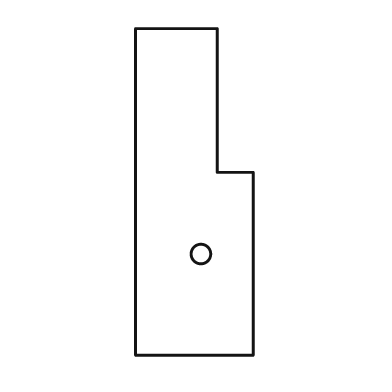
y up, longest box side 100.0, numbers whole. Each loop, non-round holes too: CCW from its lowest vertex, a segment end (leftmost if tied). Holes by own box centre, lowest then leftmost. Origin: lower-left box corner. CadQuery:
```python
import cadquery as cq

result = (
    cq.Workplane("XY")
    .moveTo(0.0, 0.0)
    .lineTo(36.0, 0.0)
    .lineTo(36.0, 56.0)
    .lineTo(25.0, 56.0)
    .lineTo(25.0, 100.0)
    .lineTo(0.0, 100.0)
    .close()
    .moveTo(20.0, 31.0)
    .circle(3.0)
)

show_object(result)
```